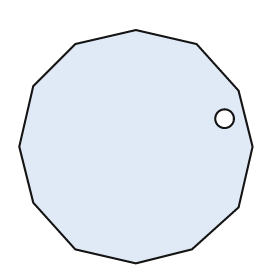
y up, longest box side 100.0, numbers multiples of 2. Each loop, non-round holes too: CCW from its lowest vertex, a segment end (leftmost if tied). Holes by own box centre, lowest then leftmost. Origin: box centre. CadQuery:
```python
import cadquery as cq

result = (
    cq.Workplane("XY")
    .moveTo(0.0, -50.0)
    .lineTo(24.0, -44.0)
    .lineTo(44.0, -26.0)
    .lineTo(50.0, 0.0)
    .lineTo(44.0, 24.0)
    .lineTo(26.0, 44.0)
    .lineTo(0.0, 50.0)
    .lineTo(-26.0, 44.0)
    .lineTo(-44.0, 26.0)
    .lineTo(-50.0, 0.0)
    .lineTo(-44.0, -24.0)
    .lineTo(-26.0, -44.0)
    .close()
    .moveTo(38.0, 12.0)
    .circle(4.0)
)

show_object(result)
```